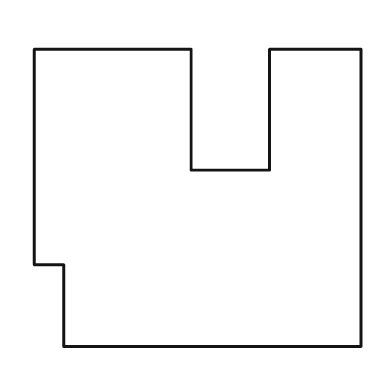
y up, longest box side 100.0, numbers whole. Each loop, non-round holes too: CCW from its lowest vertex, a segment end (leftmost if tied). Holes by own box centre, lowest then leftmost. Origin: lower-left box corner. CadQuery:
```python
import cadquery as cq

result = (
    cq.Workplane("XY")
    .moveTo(9.0, 0.0)
    .lineTo(100.0, 0.0)
    .lineTo(100.0, 91.0)
    .lineTo(72.0, 91.0)
    .lineTo(72.0, 54.0)
    .lineTo(48.0, 54.0)
    .lineTo(48.0, 91.0)
    .lineTo(0.0, 91.0)
    .lineTo(0.0, 25.0)
    .lineTo(9.0, 25.0)
    .close()
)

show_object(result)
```